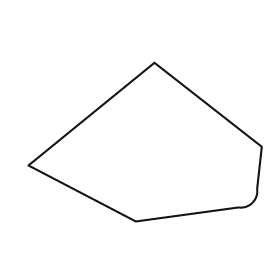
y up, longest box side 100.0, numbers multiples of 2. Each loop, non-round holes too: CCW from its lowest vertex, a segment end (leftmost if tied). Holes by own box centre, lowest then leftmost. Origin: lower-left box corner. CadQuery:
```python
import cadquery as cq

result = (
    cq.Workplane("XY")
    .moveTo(46.0, 0.0)
    .lineTo(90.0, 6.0)
    .threePointArc((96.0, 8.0), (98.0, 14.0))
    .lineTo(100.0, 32.0)
    .lineTo(54.0, 68.0)
    .lineTo(0.0, 24.0)
    .close()
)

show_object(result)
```